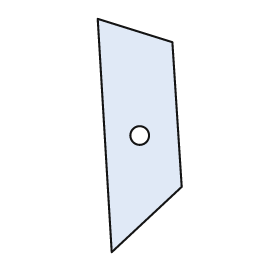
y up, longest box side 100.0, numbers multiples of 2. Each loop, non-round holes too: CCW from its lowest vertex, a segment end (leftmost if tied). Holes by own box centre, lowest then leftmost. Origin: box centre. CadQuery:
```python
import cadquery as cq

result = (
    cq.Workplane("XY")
    .moveTo(-12.0, -50.0)
    .lineTo(18.0, -22.0)
    .lineTo(14.0, 40.0)
    .lineTo(-18.0, 50.0)
    .close()
    .moveTo(0.0, 0.0)
    .circle(4.0)
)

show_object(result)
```